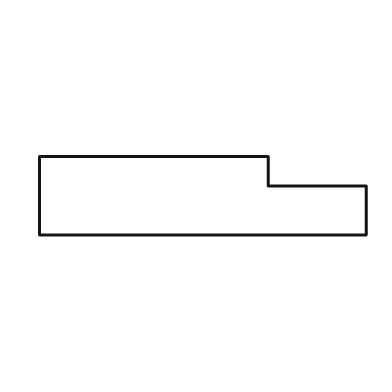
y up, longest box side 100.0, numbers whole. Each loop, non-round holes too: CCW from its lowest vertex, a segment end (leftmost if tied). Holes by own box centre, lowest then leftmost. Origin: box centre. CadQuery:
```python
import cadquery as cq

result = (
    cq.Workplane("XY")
    .moveTo(-50.0, -12.0)
    .lineTo(50.0, -12.0)
    .lineTo(50.0, 3.0)
    .lineTo(20.0, 3.0)
    .lineTo(20.0, 12.0)
    .lineTo(-50.0, 12.0)
    .close()
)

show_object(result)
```